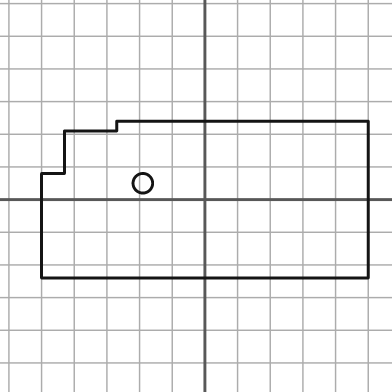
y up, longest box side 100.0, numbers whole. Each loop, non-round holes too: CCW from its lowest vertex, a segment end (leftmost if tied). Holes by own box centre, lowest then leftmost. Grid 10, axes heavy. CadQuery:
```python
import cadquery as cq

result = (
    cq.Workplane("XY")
    .moveTo(-50.0, -24.0)
    .lineTo(50.0, -24.0)
    .lineTo(50.0, 24.0)
    .lineTo(-27.0, 24.0)
    .lineTo(-27.0, 21.0)
    .lineTo(-43.0, 21.0)
    .lineTo(-43.0, 8.0)
    .lineTo(-50.0, 8.0)
    .close()
    .moveTo(-19.0, 5.0)
    .circle(3.0)
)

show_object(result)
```